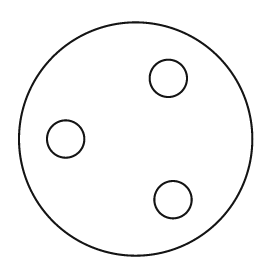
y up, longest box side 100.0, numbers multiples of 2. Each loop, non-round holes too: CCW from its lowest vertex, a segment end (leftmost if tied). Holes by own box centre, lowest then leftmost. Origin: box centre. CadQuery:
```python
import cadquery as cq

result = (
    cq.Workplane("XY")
    .moveTo(0.0, 0.0)
    .circle(50.0)
    .moveTo(16.0, -26.0)
    .circle(8.0)
    .moveTo(-30.0, 0.0)
    .circle(8.0)
    .moveTo(14.0, 26.0)
    .circle(8.0)
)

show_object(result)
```